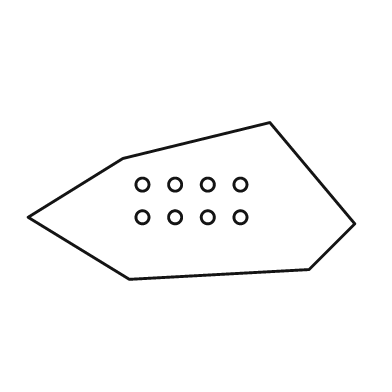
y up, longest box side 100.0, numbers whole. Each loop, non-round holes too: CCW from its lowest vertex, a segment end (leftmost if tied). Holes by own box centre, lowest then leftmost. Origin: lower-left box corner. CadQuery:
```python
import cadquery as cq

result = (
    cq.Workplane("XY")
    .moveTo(31.0, 0.0)
    .lineTo(86.0, 3.0)
    .lineTo(100.0, 17.0)
    .lineTo(74.0, 48.0)
    .lineTo(29.0, 37.0)
    .lineTo(0.0, 19.0)
    .close()
    .moveTo(35.0, 19.0)
    .circle(2.0)
    .moveTo(45.0, 19.0)
    .circle(2.0)
    .moveTo(55.0, 19.0)
    .circle(2.0)
    .moveTo(65.0, 19.0)
    .circle(2.0)
    .moveTo(35.0, 29.0)
    .circle(2.0)
    .moveTo(45.0, 29.0)
    .circle(2.0)
    .moveTo(55.0, 29.0)
    .circle(2.0)
    .moveTo(65.0, 29.0)
    .circle(2.0)
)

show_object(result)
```